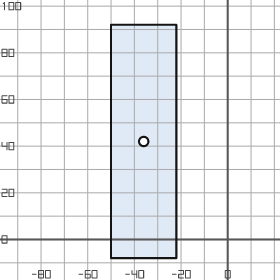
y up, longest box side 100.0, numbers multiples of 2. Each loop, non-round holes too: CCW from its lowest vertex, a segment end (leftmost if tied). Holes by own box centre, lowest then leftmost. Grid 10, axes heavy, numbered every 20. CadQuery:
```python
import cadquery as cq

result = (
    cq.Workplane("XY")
    .moveTo(-50.0, -8.0)
    .lineTo(-22.0, -8.0)
    .lineTo(-22.0, 92.0)
    .lineTo(-50.0, 92.0)
    .close()
    .moveTo(-36.0, 42.0)
    .circle(2.0)
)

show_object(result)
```